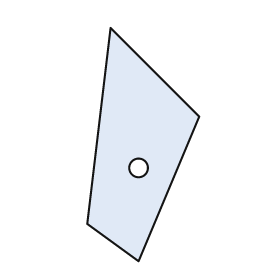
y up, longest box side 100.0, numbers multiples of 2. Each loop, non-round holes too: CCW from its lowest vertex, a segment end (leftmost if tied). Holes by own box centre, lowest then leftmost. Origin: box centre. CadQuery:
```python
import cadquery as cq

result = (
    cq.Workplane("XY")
    .moveTo(-2.0, -50.0)
    .lineTo(24.0, 12.0)
    .lineTo(-14.0, 50.0)
    .lineTo(-24.0, -34.0)
    .close()
    .moveTo(-2.0, -10.0)
    .circle(4.0)
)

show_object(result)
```